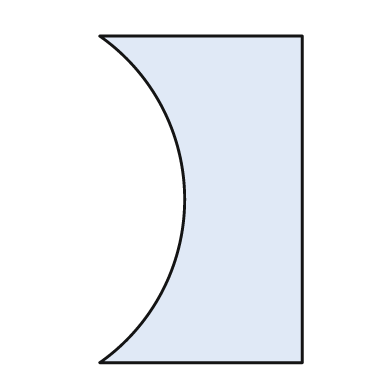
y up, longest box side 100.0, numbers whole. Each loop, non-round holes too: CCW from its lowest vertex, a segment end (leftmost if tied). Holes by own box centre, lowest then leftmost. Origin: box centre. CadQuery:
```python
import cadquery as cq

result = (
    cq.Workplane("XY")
    .moveTo(-31.0, -50.0)
    .lineTo(31.0, -50.0)
    .lineTo(31.0, 50.0)
    .lineTo(-31.0, 50.0)
    .threePointArc((-5.0, 0.0), (-31.0, -50.0))
    .close()
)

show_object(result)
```